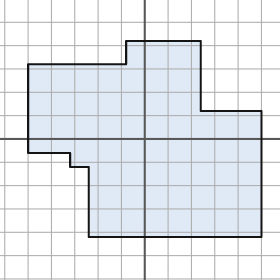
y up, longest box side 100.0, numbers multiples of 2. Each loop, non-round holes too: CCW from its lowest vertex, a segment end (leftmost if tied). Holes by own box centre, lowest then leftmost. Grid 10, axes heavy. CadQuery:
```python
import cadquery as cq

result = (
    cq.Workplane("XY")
    .moveTo(-24.0, -42.0)
    .lineTo(50.0, -42.0)
    .lineTo(50.0, 12.0)
    .lineTo(24.0, 12.0)
    .lineTo(24.0, 42.0)
    .lineTo(-8.0, 42.0)
    .lineTo(-8.0, 32.0)
    .lineTo(-50.0, 32.0)
    .lineTo(-50.0, -6.0)
    .lineTo(-32.0, -6.0)
    .lineTo(-32.0, -12.0)
    .lineTo(-24.0, -12.0)
    .close()
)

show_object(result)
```